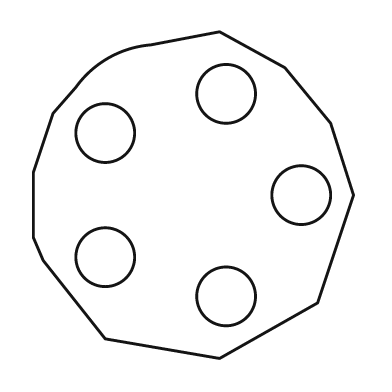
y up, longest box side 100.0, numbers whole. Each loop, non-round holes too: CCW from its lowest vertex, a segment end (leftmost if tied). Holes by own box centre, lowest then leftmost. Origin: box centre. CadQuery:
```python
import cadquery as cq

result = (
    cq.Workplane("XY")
    .moveTo(8.0, -50.0)
    .lineTo(38.0, -33.0)
    .lineTo(49.0, 0.0)
    .lineTo(42.0, 22.0)
    .lineTo(28.0, 39.0)
    .lineTo(8.0, 50.0)
    .lineTo(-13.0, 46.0)
    .threePointArc((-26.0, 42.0), (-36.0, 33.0))
    .lineTo(-43.0, 25.0)
    .lineTo(-49.0, 7.0)
    .lineTo(-49.0, -13.0)
    .lineTo(-46.0, -20.0)
    .lineTo(-27.0, -44.0)
    .close()
    .moveTo(10.0, -31.0)
    .circle(9.0)
    .moveTo(-27.0, -19.0)
    .circle(9.0)
    .moveTo(33.0, 0.0)
    .circle(9.0)
    .moveTo(-27.0, 19.0)
    .circle(9.0)
    .moveTo(10.0, 31.0)
    .circle(9.0)
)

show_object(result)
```